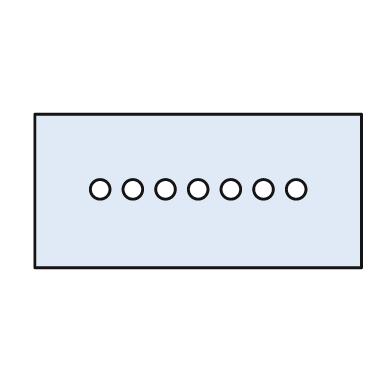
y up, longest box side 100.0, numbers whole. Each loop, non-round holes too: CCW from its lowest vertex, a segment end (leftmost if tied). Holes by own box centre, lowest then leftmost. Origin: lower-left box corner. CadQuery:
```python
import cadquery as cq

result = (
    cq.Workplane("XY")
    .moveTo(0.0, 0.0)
    .lineTo(100.0, 0.0)
    .lineTo(100.0, 47.0)
    .lineTo(0.0, 47.0)
    .close()
    .moveTo(20.0, 24.0)
    .circle(3.0)
    .moveTo(30.0, 24.0)
    .circle(3.0)
    .moveTo(40.0, 24.0)
    .circle(3.0)
    .moveTo(50.0, 24.0)
    .circle(3.0)
    .moveTo(60.0, 24.0)
    .circle(3.0)
    .moveTo(70.0, 24.0)
    .circle(3.0)
    .moveTo(80.0, 24.0)
    .circle(3.0)
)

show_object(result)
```